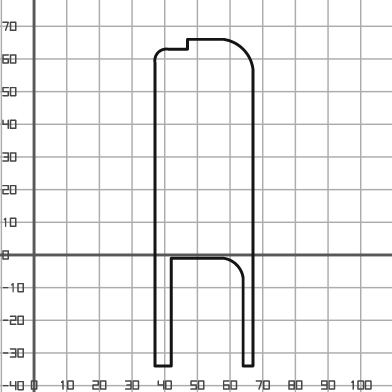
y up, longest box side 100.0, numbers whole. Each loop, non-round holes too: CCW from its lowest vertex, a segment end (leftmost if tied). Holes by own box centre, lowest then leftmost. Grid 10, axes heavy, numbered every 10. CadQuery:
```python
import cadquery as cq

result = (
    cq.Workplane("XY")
    .moveTo(37.0, -34.0)
    .lineTo(42.0, -34.0)
    .lineTo(42.0, -1.0)
    .lineTo(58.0, -1.0)
    .threePointArc((62.0, -3.0), (64.0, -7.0))
    .lineTo(64.0, -34.0)
    .lineTo(67.0, -34.0)
    .lineTo(67.0, 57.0)
    .threePointArc((64.0, 63.0), (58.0, 66.0))
    .lineTo(47.0, 66.0)
    .lineTo(47.0, 63.0)
    .lineTo(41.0, 63.0)
    .threePointArc((38.0, 62.0), (37.0, 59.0))
    .close()
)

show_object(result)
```